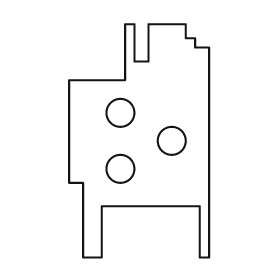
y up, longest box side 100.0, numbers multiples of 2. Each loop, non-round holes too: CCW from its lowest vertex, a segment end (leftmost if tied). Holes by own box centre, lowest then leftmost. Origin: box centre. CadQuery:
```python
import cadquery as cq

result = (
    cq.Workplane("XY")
    .moveTo(-24.0, -50.0)
    .lineTo(-16.0, -50.0)
    .lineTo(-16.0, -28.0)
    .lineTo(26.0, -28.0)
    .lineTo(26.0, -50.0)
    .lineTo(30.0, -50.0)
    .lineTo(30.0, 40.0)
    .lineTo(24.0, 40.0)
    .lineTo(24.0, 44.0)
    .lineTo(20.0, 44.0)
    .lineTo(20.0, 50.0)
    .lineTo(4.0, 50.0)
    .lineTo(4.0, 34.0)
    .lineTo(-2.0, 34.0)
    .lineTo(-2.0, 50.0)
    .lineTo(-6.0, 50.0)
    .lineTo(-6.0, 26.0)
    .lineTo(-30.0, 26.0)
    .lineTo(-30.0, -18.0)
    .lineTo(-24.0, -18.0)
    .close()
    .moveTo(-8.0, -12.0)
    .circle(6.0)
    .moveTo(14.0, 0.0)
    .circle(6.0)
    .moveTo(-8.0, 12.0)
    .circle(6.0)
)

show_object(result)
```